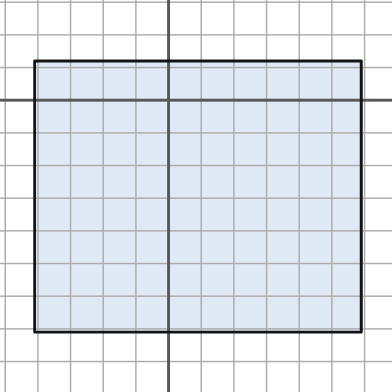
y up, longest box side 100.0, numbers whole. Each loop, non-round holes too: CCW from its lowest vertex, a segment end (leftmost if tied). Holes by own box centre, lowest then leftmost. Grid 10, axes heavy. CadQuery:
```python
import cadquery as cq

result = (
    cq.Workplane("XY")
    .moveTo(-41.0, -71.0)
    .lineTo(59.0, -71.0)
    .lineTo(59.0, 12.0)
    .lineTo(-41.0, 12.0)
    .close()
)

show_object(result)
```